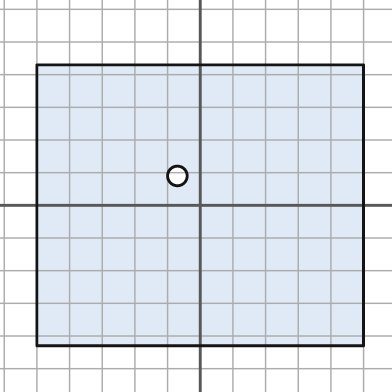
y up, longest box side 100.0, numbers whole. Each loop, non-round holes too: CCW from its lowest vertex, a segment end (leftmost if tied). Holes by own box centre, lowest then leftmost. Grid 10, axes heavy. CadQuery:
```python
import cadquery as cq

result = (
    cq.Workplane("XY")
    .moveTo(-50.0, -43.0)
    .lineTo(50.0, -43.0)
    .lineTo(50.0, 43.0)
    .lineTo(-50.0, 43.0)
    .close()
    .moveTo(-7.0, 9.0)
    .circle(3.0)
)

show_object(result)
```